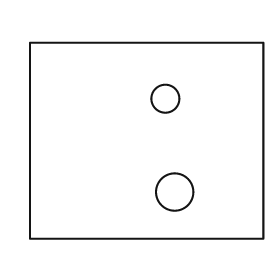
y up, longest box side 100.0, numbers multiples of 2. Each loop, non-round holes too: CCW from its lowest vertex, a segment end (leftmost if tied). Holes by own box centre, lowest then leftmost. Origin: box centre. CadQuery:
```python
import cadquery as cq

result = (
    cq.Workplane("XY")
    .moveTo(-50.0, -42.0)
    .lineTo(50.0, -42.0)
    .lineTo(50.0, 42.0)
    .lineTo(-50.0, 42.0)
    .close()
    .moveTo(12.0, -22.0)
    .circle(8.0)
    .moveTo(8.0, 18.0)
    .circle(6.0)
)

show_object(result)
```